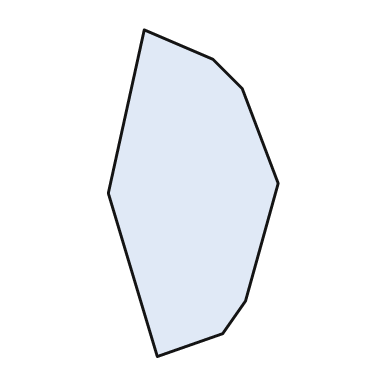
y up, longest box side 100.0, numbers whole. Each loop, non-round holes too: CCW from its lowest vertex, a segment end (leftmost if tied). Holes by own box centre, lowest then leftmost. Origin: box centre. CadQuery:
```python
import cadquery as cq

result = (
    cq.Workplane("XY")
    .moveTo(-11.0, -50.0)
    .lineTo(9.0, -43.0)
    .lineTo(16.0, -33.0)
    .lineTo(26.0, 3.0)
    .lineTo(15.0, 32.0)
    .lineTo(6.0, 41.0)
    .lineTo(-15.0, 50.0)
    .lineTo(-26.0, 0.0)
    .close()
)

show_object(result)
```